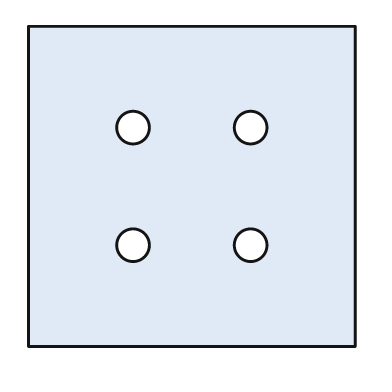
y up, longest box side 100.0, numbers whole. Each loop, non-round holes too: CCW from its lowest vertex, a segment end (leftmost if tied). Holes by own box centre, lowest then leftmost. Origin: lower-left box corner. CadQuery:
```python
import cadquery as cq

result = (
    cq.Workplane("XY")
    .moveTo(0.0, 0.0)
    .lineTo(100.0, 0.0)
    .lineTo(100.0, 98.0)
    .lineTo(0.0, 98.0)
    .close()
    .moveTo(32.0, 31.0)
    .circle(5.0)
    .moveTo(68.0, 31.0)
    .circle(5.0)
    .moveTo(32.0, 67.0)
    .circle(5.0)
    .moveTo(68.0, 67.0)
    .circle(5.0)
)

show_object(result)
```